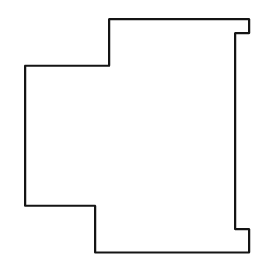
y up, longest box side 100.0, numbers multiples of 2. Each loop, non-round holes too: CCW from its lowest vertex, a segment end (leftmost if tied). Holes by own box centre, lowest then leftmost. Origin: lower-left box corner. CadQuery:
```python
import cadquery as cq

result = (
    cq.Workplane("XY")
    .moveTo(30.0, 0.0)
    .lineTo(96.0, 0.0)
    .lineTo(96.0, 10.0)
    .lineTo(90.0, 10.0)
    .lineTo(90.0, 94.0)
    .lineTo(96.0, 94.0)
    .lineTo(96.0, 100.0)
    .lineTo(36.0, 100.0)
    .lineTo(36.0, 80.0)
    .lineTo(0.0, 80.0)
    .lineTo(0.0, 20.0)
    .lineTo(30.0, 20.0)
    .close()
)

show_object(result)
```